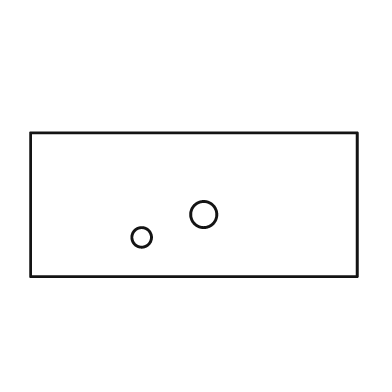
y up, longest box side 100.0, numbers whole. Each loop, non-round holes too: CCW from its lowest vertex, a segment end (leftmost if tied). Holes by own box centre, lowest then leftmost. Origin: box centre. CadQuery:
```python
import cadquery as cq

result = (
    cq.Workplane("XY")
    .moveTo(-50.0, -22.0)
    .lineTo(50.0, -22.0)
    .lineTo(50.0, 22.0)
    .lineTo(-50.0, 22.0)
    .close()
    .moveTo(-16.0, -10.0)
    .circle(3.0)
    .moveTo(3.0, -3.0)
    .circle(4.0)
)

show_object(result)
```